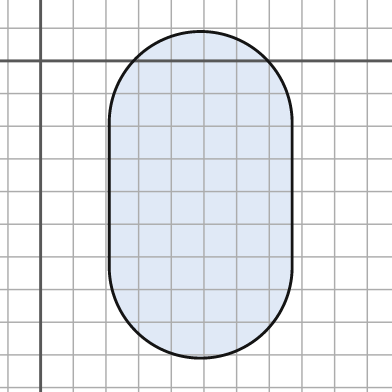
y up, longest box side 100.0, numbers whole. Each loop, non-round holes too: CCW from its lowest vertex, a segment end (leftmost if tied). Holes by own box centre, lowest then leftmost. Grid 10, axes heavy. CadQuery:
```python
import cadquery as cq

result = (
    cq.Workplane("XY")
    .moveTo(21.0, -63.0)
    .threePointArc((49.0, -91.0), (77.0, -63.0))
    .lineTo(77.0, -19.0)
    .threePointArc((49.0, 9.0), (21.0, -19.0))
    .close()
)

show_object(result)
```